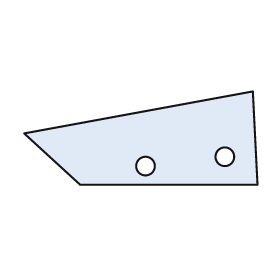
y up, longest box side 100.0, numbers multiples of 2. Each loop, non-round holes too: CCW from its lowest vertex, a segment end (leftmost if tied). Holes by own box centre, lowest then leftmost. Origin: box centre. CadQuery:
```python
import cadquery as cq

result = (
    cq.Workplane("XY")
    .moveTo(-26.0, -20.0)
    .lineTo(50.0, -20.0)
    .lineTo(48.0, 20.0)
    .lineTo(-50.0, 2.0)
    .close()
    .moveTo(2.0, -12.0)
    .circle(4.0)
    .moveTo(36.0, -8.0)
    .circle(4.0)
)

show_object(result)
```